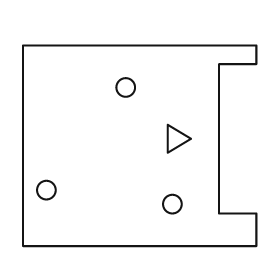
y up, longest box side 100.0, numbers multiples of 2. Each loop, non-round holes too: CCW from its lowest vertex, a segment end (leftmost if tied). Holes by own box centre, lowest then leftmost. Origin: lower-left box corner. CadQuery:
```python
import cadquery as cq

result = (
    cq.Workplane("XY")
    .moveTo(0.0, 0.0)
    .lineTo(100.0, 0.0)
    .lineTo(100.0, 14.0)
    .lineTo(84.0, 14.0)
    .lineTo(84.0, 78.0)
    .lineTo(100.0, 78.0)
    .lineTo(100.0, 86.0)
    .lineTo(0.0, 86.0)
    .close()
    .moveTo(64.0, 18.0)
    .circle(4.0)
    .moveTo(10.0, 24.0)
    .circle(4.0)
    .moveTo(62.0, 40.0)
    .lineTo(72.0, 46.0)
    .lineTo(62.0, 52.0)
    .close()
    .moveTo(44.0, 68.0)
    .circle(4.0)
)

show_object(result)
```